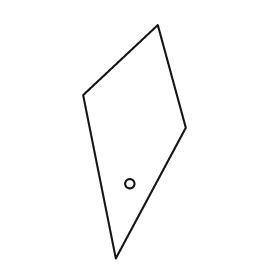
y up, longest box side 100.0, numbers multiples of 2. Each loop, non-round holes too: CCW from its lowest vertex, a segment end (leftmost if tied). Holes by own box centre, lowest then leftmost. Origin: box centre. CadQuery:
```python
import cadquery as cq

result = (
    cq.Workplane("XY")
    .moveTo(-8.0, -50.0)
    .lineTo(22.0, 6.0)
    .lineTo(10.0, 50.0)
    .lineTo(-22.0, 20.0)
    .close()
    .moveTo(-2.0, -18.0)
    .circle(2.0)
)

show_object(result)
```